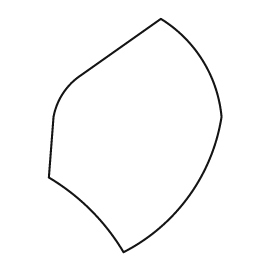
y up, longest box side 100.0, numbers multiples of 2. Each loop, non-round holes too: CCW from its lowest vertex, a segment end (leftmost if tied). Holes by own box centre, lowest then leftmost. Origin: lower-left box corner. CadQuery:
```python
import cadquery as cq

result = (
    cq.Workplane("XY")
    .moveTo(32.0, 0.0)
    .threePointArc((60.0, 24.0), (74.0, 58.0))
    .threePointArc((66.0, 82.0), (48.0, 100.0))
    .lineTo(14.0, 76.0)
    .threePointArc((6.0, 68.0), (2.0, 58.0))
    .lineTo(0.0, 32.0)
    .threePointArc((18.0, 18.0), (32.0, 0.0))
    .close()
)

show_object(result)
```